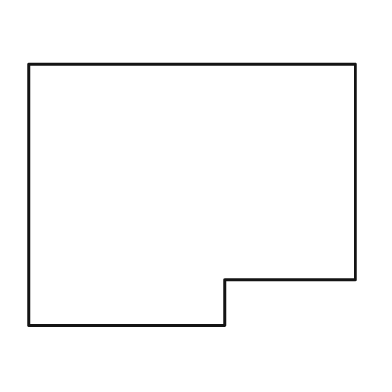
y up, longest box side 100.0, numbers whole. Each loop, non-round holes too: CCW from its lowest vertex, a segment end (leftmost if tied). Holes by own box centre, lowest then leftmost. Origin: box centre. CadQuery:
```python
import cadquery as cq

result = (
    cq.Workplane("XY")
    .moveTo(-50.0, -40.0)
    .lineTo(10.0, -40.0)
    .lineTo(10.0, -26.0)
    .lineTo(50.0, -26.0)
    .lineTo(50.0, 40.0)
    .lineTo(-50.0, 40.0)
    .close()
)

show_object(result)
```